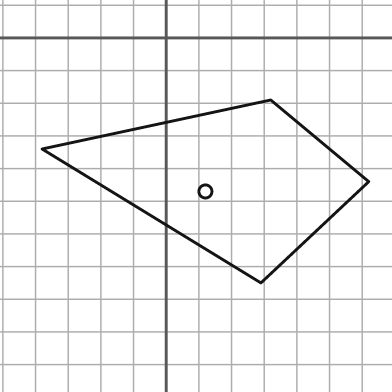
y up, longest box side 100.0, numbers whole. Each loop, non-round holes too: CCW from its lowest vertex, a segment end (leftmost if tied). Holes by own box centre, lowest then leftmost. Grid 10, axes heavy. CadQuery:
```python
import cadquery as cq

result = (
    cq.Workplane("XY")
    .moveTo(29.0, -75.0)
    .lineTo(62.0, -44.0)
    .lineTo(32.0, -19.0)
    .lineTo(-38.0, -34.0)
    .close()
    .moveTo(12.0, -47.0)
    .circle(2.0)
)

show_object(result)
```